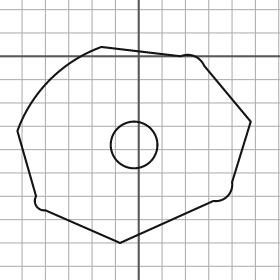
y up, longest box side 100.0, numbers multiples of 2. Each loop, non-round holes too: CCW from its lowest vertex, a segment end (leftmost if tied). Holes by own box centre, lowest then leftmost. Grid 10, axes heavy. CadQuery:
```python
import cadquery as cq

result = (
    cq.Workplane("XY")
    .moveTo(-8.0, -80.0)
    .lineTo(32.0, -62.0)
    .threePointArc((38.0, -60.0), (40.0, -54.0))
    .lineTo(48.0, -28.0)
    .lineTo(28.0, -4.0)
    .threePointArc((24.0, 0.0), (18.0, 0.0))
    .lineTo(-16.0, 4.0)
    .threePointArc((-38.0, -10.0), (-52.0, -32.0))
    .lineTo(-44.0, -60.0)
    .threePointArc((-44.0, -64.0), (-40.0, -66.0))
    .close()
    .moveTo(-2.0, -38.0)
    .circle(10.0)
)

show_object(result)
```